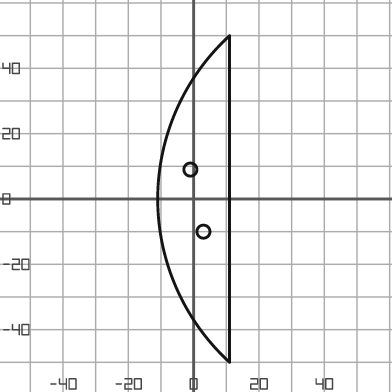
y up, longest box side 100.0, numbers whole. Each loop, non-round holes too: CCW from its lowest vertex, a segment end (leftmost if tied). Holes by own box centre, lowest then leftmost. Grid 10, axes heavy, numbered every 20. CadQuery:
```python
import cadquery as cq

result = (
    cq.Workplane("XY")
    .moveTo(11.0, -50.0)
    .lineTo(11.0, 50.0)
    .threePointArc((-11.0, 0.0), (11.0, -50.0))
    .close()
    .moveTo(3.0, -10.0)
    .circle(2.0)
    .moveTo(-1.0, 9.0)
    .circle(2.0)
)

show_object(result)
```